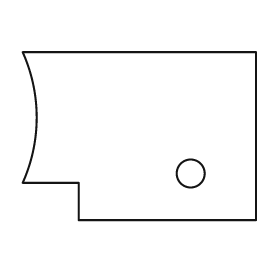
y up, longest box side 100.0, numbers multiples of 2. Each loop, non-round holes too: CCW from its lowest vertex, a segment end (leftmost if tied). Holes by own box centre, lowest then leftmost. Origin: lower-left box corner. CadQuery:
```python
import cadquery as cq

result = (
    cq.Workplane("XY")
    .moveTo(24.0, 0.0)
    .lineTo(100.0, 0.0)
    .lineTo(100.0, 72.0)
    .lineTo(0.0, 72.0)
    .threePointArc((6.0, 44.0), (0.0, 16.0))
    .lineTo(24.0, 16.0)
    .close()
    .moveTo(72.0, 20.0)
    .circle(6.0)
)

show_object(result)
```